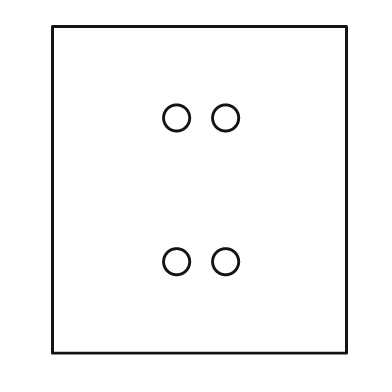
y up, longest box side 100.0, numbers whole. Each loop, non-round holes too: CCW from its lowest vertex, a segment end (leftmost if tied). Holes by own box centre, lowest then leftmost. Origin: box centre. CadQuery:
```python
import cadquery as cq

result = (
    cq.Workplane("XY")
    .moveTo(-45.0, -50.0)
    .lineTo(45.0, -50.0)
    .lineTo(45.0, 50.0)
    .lineTo(-45.0, 50.0)
    .close()
    .moveTo(-7.0, -22.0)
    .circle(4.0)
    .moveTo(8.0, -22.0)
    .circle(4.0)
    .moveTo(-7.0, 22.0)
    .circle(4.0)
    .moveTo(8.0, 22.0)
    .circle(4.0)
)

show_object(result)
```